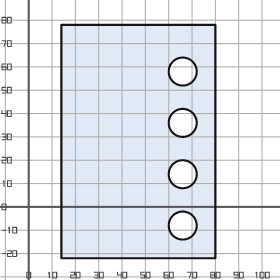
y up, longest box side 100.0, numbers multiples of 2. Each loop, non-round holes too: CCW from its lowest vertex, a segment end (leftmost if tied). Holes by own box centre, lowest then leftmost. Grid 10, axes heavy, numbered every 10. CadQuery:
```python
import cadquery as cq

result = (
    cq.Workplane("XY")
    .moveTo(14.0, -22.0)
    .lineTo(80.0, -22.0)
    .lineTo(80.0, 78.0)
    .lineTo(14.0, 78.0)
    .close()
    .moveTo(66.0, -8.0)
    .circle(6.0)
    .moveTo(66.0, 14.0)
    .circle(6.0)
    .moveTo(66.0, 36.0)
    .circle(6.0)
    .moveTo(66.0, 58.0)
    .circle(6.0)
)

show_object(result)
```